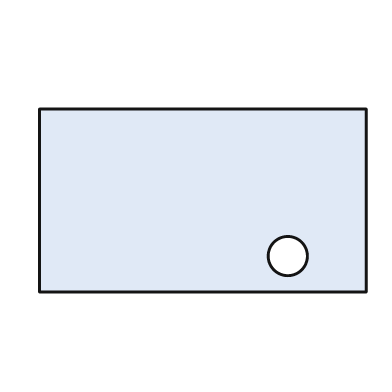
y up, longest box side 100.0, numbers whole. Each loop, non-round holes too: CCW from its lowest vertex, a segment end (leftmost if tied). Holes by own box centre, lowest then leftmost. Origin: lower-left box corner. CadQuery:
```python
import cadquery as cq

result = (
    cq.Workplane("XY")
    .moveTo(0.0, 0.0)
    .lineTo(100.0, 0.0)
    .lineTo(100.0, 56.0)
    .lineTo(0.0, 56.0)
    .close()
    .moveTo(76.0, 11.0)
    .circle(6.0)
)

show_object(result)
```